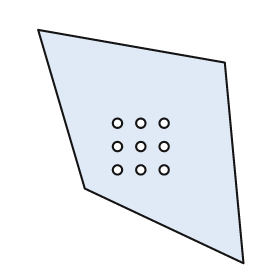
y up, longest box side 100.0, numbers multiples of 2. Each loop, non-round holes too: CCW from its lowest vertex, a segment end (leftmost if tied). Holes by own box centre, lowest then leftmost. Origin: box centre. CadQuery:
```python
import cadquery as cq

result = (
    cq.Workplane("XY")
    .moveTo(44.0, -50.0)
    .lineTo(36.0, 36.0)
    .lineTo(-44.0, 50.0)
    .lineTo(-24.0, -18.0)
    .close()
    .moveTo(-10.0, -10.0)
    .circle(2.0)
    .moveTo(0.0, -10.0)
    .circle(2.0)
    .moveTo(10.0, -10.0)
    .circle(2.0)
    .moveTo(-10.0, 0.0)
    .circle(2.0)
    .moveTo(0.0, 0.0)
    .circle(2.0)
    .moveTo(10.0, 0.0)
    .circle(2.0)
    .moveTo(-10.0, 10.0)
    .circle(2.0)
    .moveTo(0.0, 10.0)
    .circle(2.0)
    .moveTo(10.0, 10.0)
    .circle(2.0)
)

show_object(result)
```